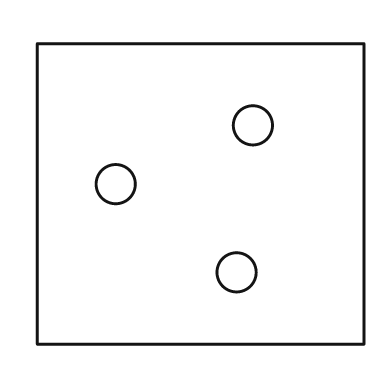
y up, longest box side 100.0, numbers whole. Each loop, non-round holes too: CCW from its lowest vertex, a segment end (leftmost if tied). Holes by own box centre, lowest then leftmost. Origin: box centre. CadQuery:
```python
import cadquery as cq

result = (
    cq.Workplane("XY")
    .moveTo(-50.0, -46.0)
    .lineTo(50.0, -46.0)
    .lineTo(50.0, 46.0)
    .lineTo(-50.0, 46.0)
    .close()
    .moveTo(11.0, -24.0)
    .circle(6.0)
    .moveTo(-26.0, 3.0)
    .circle(6.0)
    .moveTo(16.0, 21.0)
    .circle(6.0)
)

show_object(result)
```